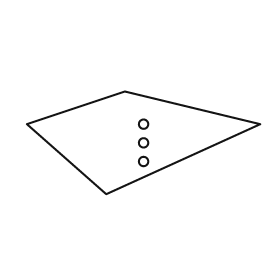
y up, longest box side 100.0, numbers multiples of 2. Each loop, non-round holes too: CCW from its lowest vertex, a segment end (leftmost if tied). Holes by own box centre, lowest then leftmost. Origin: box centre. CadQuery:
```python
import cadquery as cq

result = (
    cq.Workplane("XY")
    .moveTo(-16.0, -22.0)
    .lineTo(50.0, 8.0)
    .lineTo(-8.0, 22.0)
    .lineTo(-50.0, 8.0)
    .close()
    .moveTo(0.0, -8.0)
    .circle(2.0)
    .moveTo(0.0, 0.0)
    .circle(2.0)
    .moveTo(0.0, 8.0)
    .circle(2.0)
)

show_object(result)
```